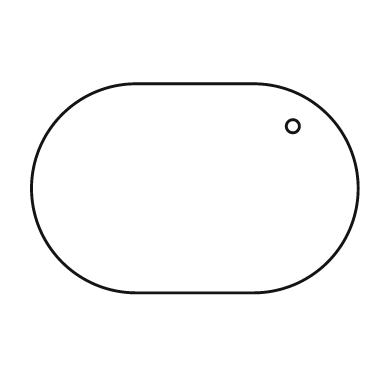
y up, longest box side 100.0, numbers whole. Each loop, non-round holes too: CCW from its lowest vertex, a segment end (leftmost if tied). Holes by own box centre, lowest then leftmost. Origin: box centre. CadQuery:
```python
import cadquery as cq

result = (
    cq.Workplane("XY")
    .moveTo(-18.0, -32.0)
    .lineTo(18.0, -32.0)
    .threePointArc((50.0, 0.0), (18.0, 32.0))
    .lineTo(-18.0, 32.0)
    .threePointArc((-50.0, 0.0), (-18.0, -32.0))
    .close()
    .moveTo(30.0, 19.0)
    .circle(2.0)
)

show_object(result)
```